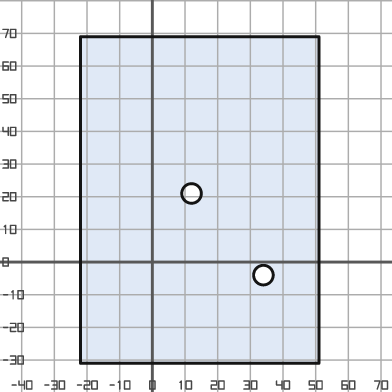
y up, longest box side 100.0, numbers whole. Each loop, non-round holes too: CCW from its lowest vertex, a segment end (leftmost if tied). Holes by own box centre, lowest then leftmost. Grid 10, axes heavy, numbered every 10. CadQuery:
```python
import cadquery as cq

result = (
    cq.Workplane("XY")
    .moveTo(-22.0, -31.0)
    .lineTo(51.0, -31.0)
    .lineTo(51.0, 69.0)
    .lineTo(-22.0, 69.0)
    .close()
    .moveTo(34.0, -4.0)
    .circle(3.0)
    .moveTo(12.0, 21.0)
    .circle(3.0)
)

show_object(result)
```